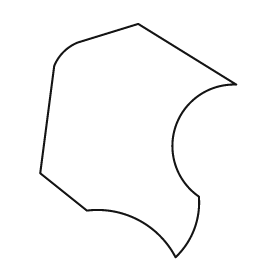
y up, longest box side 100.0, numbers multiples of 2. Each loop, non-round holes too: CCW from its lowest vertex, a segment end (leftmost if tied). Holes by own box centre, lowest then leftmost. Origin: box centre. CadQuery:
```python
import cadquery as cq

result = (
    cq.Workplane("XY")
    .moveTo(16.0, -50.0)
    .threePointArc((24.0, -38.0), (26.0, -24.0))
    .threePointArc((16.0, 6.0), (42.0, 24.0))
    .lineTo(0.0, 50.0)
    .lineTo(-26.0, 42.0)
    .threePointArc((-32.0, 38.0), (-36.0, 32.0))
    .lineTo(-42.0, -14.0)
    .lineTo(-22.0, -30.0)
    .threePointArc((0.0, -34.0), (16.0, -50.0))
    .close()
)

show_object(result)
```